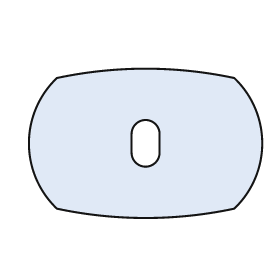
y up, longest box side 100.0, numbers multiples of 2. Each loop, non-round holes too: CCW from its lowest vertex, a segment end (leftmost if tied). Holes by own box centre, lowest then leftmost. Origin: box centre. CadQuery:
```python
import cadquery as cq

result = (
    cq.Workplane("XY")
    .moveTo(-38.0, -28.0)
    .threePointArc((0.0, -32.0), (38.0, -28.0))
    .threePointArc((50.0, 0.0), (38.0, 28.0))
    .threePointArc((0.0, 32.0), (-38.0, 28.0))
    .threePointArc((-50.0, 0.0), (-38.0, -28.0))
    .close()
    .moveTo(-6.0, -4.0)
    .threePointArc((0.0, -10.0), (6.0, -4.0))
    .lineTo(6.0, 4.0)
    .threePointArc((0.0, 10.0), (-6.0, 4.0))
    .close()
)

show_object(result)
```